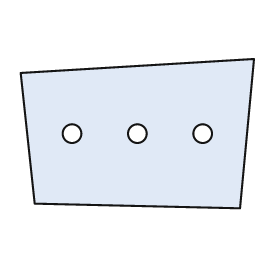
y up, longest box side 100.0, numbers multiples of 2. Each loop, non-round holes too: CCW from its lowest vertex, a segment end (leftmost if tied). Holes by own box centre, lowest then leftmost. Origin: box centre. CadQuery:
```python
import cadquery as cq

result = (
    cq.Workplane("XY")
    .moveTo(44.0, -32.0)
    .lineTo(50.0, 32.0)
    .lineTo(-50.0, 26.0)
    .lineTo(-44.0, -30.0)
    .close()
    .moveTo(-28.0, 0.0)
    .circle(4.0)
    .moveTo(0.0, 0.0)
    .circle(4.0)
    .moveTo(28.0, 0.0)
    .circle(4.0)
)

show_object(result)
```